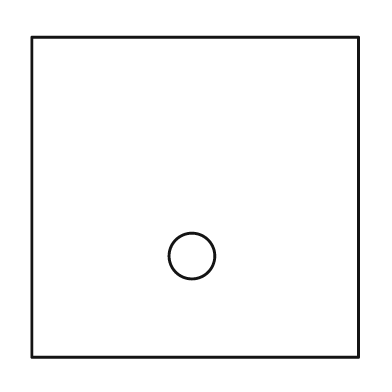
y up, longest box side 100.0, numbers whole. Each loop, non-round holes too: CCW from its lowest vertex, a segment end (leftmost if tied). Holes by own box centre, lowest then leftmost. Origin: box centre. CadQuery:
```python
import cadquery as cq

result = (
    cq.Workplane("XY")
    .moveTo(-50.0, -49.0)
    .lineTo(50.0, -49.0)
    .lineTo(50.0, 49.0)
    .lineTo(-50.0, 49.0)
    .close()
    .moveTo(-1.0, -18.0)
    .circle(7.0)
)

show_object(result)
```